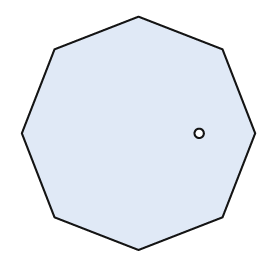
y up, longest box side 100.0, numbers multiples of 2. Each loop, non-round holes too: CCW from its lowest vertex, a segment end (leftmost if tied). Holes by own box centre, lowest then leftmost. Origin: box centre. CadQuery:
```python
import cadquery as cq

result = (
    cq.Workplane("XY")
    .moveTo(0.0, -50.0)
    .lineTo(36.0, -36.0)
    .lineTo(50.0, 0.0)
    .lineTo(36.0, 36.0)
    .lineTo(0.0, 50.0)
    .lineTo(-36.0, 36.0)
    .lineTo(-50.0, 0.0)
    .lineTo(-36.0, -36.0)
    .close()
    .moveTo(26.0, 0.0)
    .circle(2.0)
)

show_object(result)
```